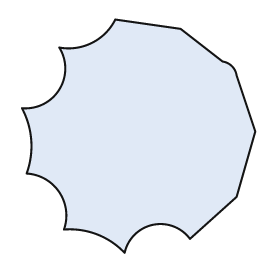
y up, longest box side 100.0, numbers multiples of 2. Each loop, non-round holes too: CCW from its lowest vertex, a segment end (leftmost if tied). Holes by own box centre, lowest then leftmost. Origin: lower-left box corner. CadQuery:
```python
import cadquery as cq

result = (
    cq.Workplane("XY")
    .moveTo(44.0, 0.0)
    .threePointArc((56.0, 12.0), (72.0, 6.0))
    .lineTo(92.0, 24.0)
    .lineTo(100.0, 52.0)
    .lineTo(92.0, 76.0)
    .threePointArc((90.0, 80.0), (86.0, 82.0))
    .lineTo(68.0, 96.0)
    .lineTo(40.0, 100.0)
    .threePointArc((30.0, 90.0), (16.0, 88.0))
    .threePointArc((16.0, 70.0), (0.0, 62.0))
    .threePointArc((4.0, 48.0), (2.0, 34.0))
    .threePointArc((16.0, 26.0), (18.0, 10.0))
    .threePointArc((32.0, 8.0), (44.0, 0.0))
    .close()
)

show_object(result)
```